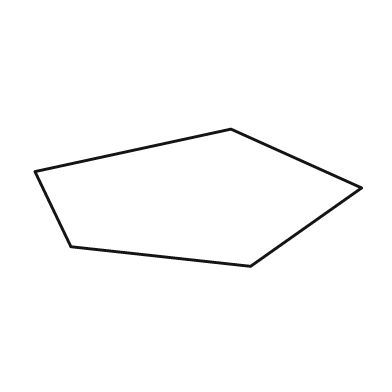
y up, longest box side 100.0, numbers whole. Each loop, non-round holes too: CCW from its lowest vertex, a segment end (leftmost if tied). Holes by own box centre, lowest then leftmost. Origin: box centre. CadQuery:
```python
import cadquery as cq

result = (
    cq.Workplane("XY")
    .moveTo(16.0, -21.0)
    .lineTo(50.0, 3.0)
    .lineTo(10.0, 21.0)
    .lineTo(-50.0, 8.0)
    .lineTo(-39.0, -15.0)
    .close()
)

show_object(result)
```